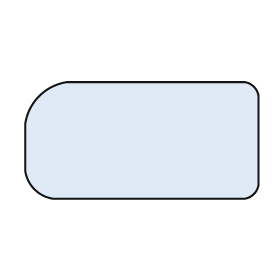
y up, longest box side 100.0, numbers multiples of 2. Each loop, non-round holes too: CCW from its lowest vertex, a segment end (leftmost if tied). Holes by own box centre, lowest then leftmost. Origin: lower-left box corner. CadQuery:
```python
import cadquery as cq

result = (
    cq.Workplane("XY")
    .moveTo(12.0, 0.0)
    .lineTo(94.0, 0.0)
    .threePointArc((98.0, 2.0), (100.0, 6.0))
    .lineTo(100.0, 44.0)
    .threePointArc((98.0, 48.0), (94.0, 50.0))
    .lineTo(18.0, 50.0)
    .threePointArc((6.0, 44.0), (0.0, 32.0))
    .lineTo(0.0, 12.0)
    .threePointArc((4.0, 4.0), (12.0, 0.0))
    .close()
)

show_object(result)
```